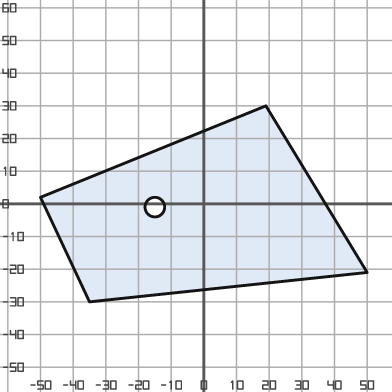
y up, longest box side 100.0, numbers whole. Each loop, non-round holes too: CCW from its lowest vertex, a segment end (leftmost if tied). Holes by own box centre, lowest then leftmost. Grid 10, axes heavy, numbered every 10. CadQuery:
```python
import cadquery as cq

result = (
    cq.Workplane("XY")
    .moveTo(-35.0, -30.0)
    .lineTo(50.0, -21.0)
    .lineTo(19.0, 30.0)
    .lineTo(-50.0, 2.0)
    .close()
    .moveTo(-15.0, -1.0)
    .circle(3.0)
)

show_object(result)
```